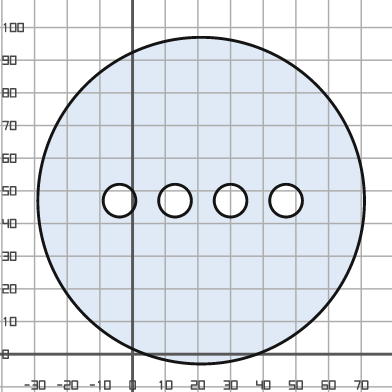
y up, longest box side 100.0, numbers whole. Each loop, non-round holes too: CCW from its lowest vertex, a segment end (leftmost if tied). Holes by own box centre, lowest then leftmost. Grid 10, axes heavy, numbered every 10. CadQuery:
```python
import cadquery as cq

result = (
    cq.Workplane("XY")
    .moveTo(21.0, 47.0)
    .circle(50.0)
    .moveTo(-4.0, 47.0)
    .circle(5.0)
    .moveTo(13.0, 47.0)
    .circle(5.0)
    .moveTo(30.0, 47.0)
    .circle(5.0)
    .moveTo(47.0, 47.0)
    .circle(5.0)
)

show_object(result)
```